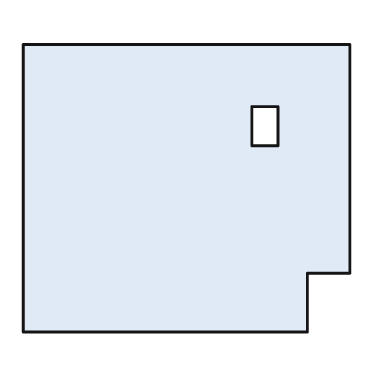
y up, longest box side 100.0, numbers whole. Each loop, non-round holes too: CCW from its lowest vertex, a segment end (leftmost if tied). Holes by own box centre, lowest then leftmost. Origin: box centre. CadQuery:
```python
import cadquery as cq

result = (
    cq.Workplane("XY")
    .moveTo(-50.0, -44.0)
    .lineTo(37.0, -44.0)
    .lineTo(37.0, -26.0)
    .lineTo(50.0, -26.0)
    .lineTo(50.0, 44.0)
    .lineTo(-50.0, 44.0)
    .close()
    .moveTo(20.0, 13.0)
    .lineTo(28.0, 13.0)
    .lineTo(28.0, 25.0)
    .lineTo(20.0, 25.0)
    .close()
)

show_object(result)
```